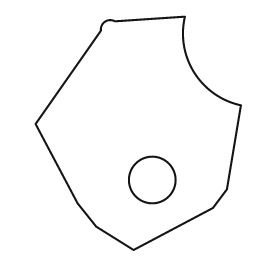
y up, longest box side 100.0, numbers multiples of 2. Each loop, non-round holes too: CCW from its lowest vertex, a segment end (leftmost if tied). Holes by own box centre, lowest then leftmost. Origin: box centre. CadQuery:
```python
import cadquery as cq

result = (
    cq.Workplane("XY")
    .moveTo(-2.0, -50.0)
    .lineTo(32.0, -32.0)
    .lineTo(38.0, -24.0)
    .lineTo(44.0, 12.0)
    .threePointArc((24.0, 26.0), (20.0, 50.0))
    .lineTo(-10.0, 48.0)
    .threePointArc((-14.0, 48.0), (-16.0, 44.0))
    .lineTo(-44.0, 4.0)
    .lineTo(-26.0, -30.0)
    .lineTo(-18.0, -40.0)
    .close()
    .moveTo(6.0, -20.0)
    .circle(10.0)
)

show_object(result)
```